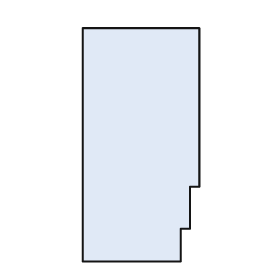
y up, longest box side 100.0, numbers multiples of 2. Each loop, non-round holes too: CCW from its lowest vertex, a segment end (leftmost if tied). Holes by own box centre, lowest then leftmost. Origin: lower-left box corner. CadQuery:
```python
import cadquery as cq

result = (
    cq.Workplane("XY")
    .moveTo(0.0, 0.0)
    .lineTo(42.0, 0.0)
    .lineTo(42.0, 14.0)
    .lineTo(46.0, 14.0)
    .lineTo(46.0, 32.0)
    .lineTo(50.0, 32.0)
    .lineTo(50.0, 100.0)
    .lineTo(0.0, 100.0)
    .close()
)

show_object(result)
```